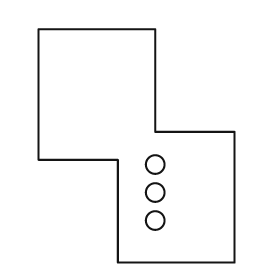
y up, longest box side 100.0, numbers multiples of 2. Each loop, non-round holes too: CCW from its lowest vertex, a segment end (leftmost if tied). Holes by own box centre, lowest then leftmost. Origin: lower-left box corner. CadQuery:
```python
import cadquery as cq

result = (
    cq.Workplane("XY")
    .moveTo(34.0, 0.0)
    .lineTo(84.0, 0.0)
    .lineTo(84.0, 56.0)
    .lineTo(50.0, 56.0)
    .lineTo(50.0, 100.0)
    .lineTo(0.0, 100.0)
    .lineTo(0.0, 44.0)
    .lineTo(34.0, 44.0)
    .close()
    .moveTo(50.0, 18.0)
    .circle(4.0)
    .moveTo(50.0, 30.0)
    .circle(4.0)
    .moveTo(50.0, 42.0)
    .circle(4.0)
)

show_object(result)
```